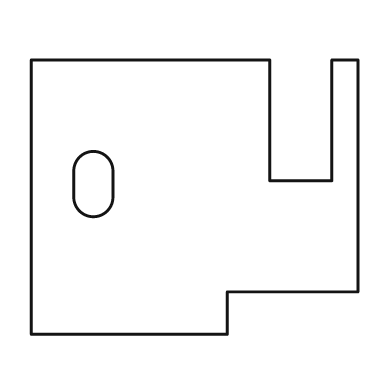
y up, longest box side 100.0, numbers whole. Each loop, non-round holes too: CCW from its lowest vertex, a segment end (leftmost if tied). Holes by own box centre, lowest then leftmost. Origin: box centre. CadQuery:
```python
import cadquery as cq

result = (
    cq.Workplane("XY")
    .moveTo(-50.0, -42.0)
    .lineTo(10.0, -42.0)
    .lineTo(10.0, -29.0)
    .lineTo(50.0, -29.0)
    .lineTo(50.0, 42.0)
    .lineTo(42.0, 42.0)
    .lineTo(42.0, 5.0)
    .lineTo(23.0, 5.0)
    .lineTo(23.0, 42.0)
    .lineTo(-50.0, 42.0)
    .close()
    .moveTo(-37.0, 0.0)
    .threePointArc((-31.0, -6.0), (-25.0, 0.0))
    .lineTo(-25.0, 8.0)
    .threePointArc((-31.0, 14.0), (-37.0, 8.0))
    .close()
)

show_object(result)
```